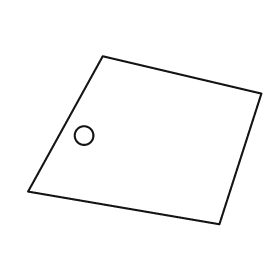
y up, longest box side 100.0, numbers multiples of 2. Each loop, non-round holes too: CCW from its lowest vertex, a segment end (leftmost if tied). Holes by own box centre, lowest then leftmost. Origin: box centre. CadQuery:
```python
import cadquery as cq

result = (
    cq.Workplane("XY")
    .moveTo(32.0, -36.0)
    .lineTo(50.0, 20.0)
    .lineTo(-18.0, 36.0)
    .lineTo(-50.0, -22.0)
    .close()
    .moveTo(-26.0, 2.0)
    .circle(4.0)
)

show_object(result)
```